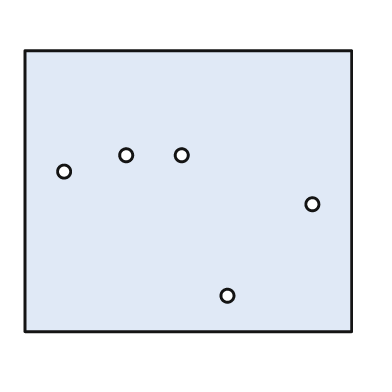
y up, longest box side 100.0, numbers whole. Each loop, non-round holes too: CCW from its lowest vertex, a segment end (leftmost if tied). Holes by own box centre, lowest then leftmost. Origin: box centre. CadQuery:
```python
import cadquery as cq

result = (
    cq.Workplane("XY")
    .moveTo(-50.0, -43.0)
    .lineTo(50.0, -43.0)
    .lineTo(50.0, 43.0)
    .lineTo(-50.0, 43.0)
    .close()
    .moveTo(12.0, -32.0)
    .circle(2.0)
    .moveTo(38.0, -4.0)
    .circle(2.0)
    .moveTo(-38.0, 6.0)
    .circle(2.0)
    .moveTo(-19.0, 11.0)
    .circle(2.0)
    .moveTo(-2.0, 11.0)
    .circle(2.0)
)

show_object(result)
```